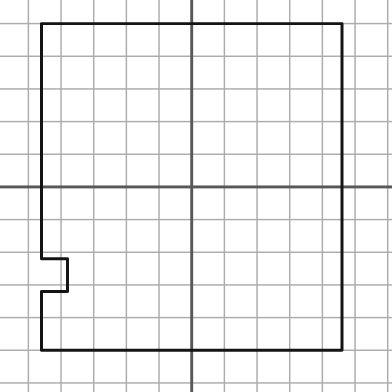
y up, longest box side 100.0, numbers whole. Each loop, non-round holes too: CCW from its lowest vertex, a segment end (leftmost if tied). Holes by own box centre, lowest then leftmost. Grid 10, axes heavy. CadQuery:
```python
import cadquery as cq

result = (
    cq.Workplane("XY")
    .moveTo(-46.0, -50.0)
    .lineTo(46.0, -50.0)
    .lineTo(46.0, 50.0)
    .lineTo(-46.0, 50.0)
    .lineTo(-46.0, -22.0)
    .lineTo(-38.0, -22.0)
    .lineTo(-38.0, -32.0)
    .lineTo(-46.0, -32.0)
    .close()
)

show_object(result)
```